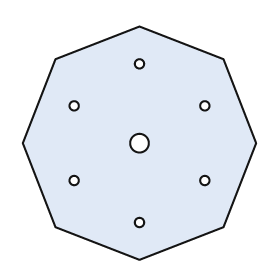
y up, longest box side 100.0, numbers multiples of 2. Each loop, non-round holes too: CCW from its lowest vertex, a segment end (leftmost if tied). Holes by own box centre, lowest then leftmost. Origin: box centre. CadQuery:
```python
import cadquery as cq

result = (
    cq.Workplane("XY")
    .moveTo(0.0, -50.0)
    .lineTo(36.0, -36.0)
    .lineTo(50.0, 0.0)
    .lineTo(36.0, 36.0)
    .lineTo(0.0, 50.0)
    .lineTo(-36.0, 36.0)
    .lineTo(-50.0, 0.0)
    .lineTo(-36.0, -36.0)
    .close()
    .moveTo(0.0, -34.0)
    .circle(2.0)
    .moveTo(-28.0, -16.0)
    .circle(2.0)
    .moveTo(28.0, -16.0)
    .circle(2.0)
    .moveTo(0.0, 0.0)
    .circle(4.0)
    .moveTo(-28.0, 16.0)
    .circle(2.0)
    .moveTo(28.0, 16.0)
    .circle(2.0)
    .moveTo(0.0, 34.0)
    .circle(2.0)
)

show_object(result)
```